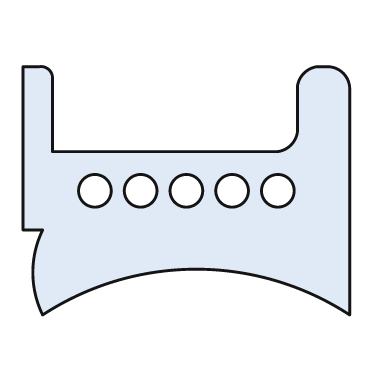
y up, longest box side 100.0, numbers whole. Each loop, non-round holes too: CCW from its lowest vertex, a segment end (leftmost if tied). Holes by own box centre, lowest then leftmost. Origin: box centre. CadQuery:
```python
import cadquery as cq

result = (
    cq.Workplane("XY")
    .moveTo(-44.0, -38.0)
    .threePointArc((3.0, -24.0), (50.0, -38.0))
    .lineTo(50.0, 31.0)
    .threePointArc((48.0, 36.0), (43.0, 38.0))
    .lineTo(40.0, 38.0)
    .threePointArc((36.0, 36.0), (34.0, 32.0))
    .lineTo(34.0, 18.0)
    .threePointArc((32.0, 14.0), (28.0, 12.0))
    .lineTo(-41.0, 12.0)
    .lineTo(-41.0, 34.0)
    .threePointArc((-42.0, 37.0), (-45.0, 38.0))
    .lineTo(-50.0, 38.0)
    .lineTo(-50.0, -12.0)
    .lineTo(-44.0, -12.0)
    .threePointArc((-47.0, -25.0), (-44.0, -38.0))
    .close()
    .moveTo(-28.0, 0.0)
    .circle(5.0)
    .moveTo(-14.0, 0.0)
    .circle(5.0)
    .moveTo(0.0, 0.0)
    .circle(5.0)
    .moveTo(14.0, 0.0)
    .circle(5.0)
    .moveTo(28.0, 0.0)
    .circle(5.0)
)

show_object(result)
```